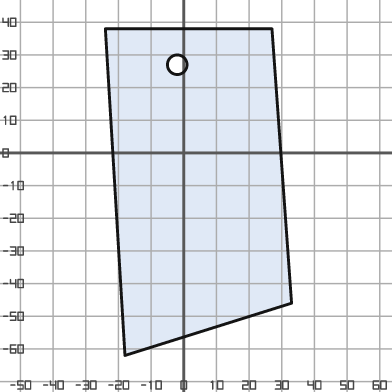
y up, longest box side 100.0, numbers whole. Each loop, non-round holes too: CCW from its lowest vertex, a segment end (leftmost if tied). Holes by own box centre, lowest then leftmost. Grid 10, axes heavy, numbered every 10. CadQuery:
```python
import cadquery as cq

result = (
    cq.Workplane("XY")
    .moveTo(-18.0, -62.0)
    .lineTo(33.0, -46.0)
    .lineTo(27.0, 38.0)
    .lineTo(-24.0, 38.0)
    .close()
    .moveTo(-2.0, 27.0)
    .circle(3.0)
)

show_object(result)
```